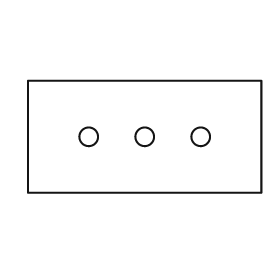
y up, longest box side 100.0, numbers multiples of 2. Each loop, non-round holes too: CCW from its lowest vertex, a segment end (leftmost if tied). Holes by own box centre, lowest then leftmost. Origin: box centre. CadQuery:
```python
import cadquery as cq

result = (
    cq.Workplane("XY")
    .moveTo(-50.0, -24.0)
    .lineTo(50.0, -24.0)
    .lineTo(50.0, 24.0)
    .lineTo(-50.0, 24.0)
    .close()
    .moveTo(-24.0, 0.0)
    .circle(4.0)
    .moveTo(0.0, 0.0)
    .circle(4.0)
    .moveTo(24.0, 0.0)
    .circle(4.0)
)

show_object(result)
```